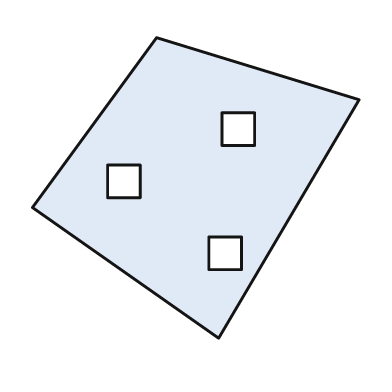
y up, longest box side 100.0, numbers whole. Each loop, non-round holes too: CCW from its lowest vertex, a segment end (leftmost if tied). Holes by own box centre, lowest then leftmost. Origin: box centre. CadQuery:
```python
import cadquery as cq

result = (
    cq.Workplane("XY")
    .moveTo(7.0, -46.0)
    .lineTo(50.0, 27.0)
    .lineTo(-12.0, 46.0)
    .lineTo(-50.0, -6.0)
    .close()
    .moveTo(4.0, -25.0)
    .lineTo(14.0, -25.0)
    .lineTo(14.0, -15.0)
    .lineTo(4.0, -15.0)
    .close()
    .moveTo(-27.0, -3.0)
    .lineTo(-17.0, -3.0)
    .lineTo(-17.0, 7.0)
    .lineTo(-27.0, 7.0)
    .close()
    .moveTo(8.0, 13.0)
    .lineTo(18.0, 13.0)
    .lineTo(18.0, 23.0)
    .lineTo(8.0, 23.0)
    .close()
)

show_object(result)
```